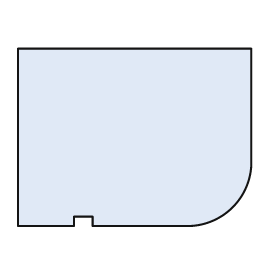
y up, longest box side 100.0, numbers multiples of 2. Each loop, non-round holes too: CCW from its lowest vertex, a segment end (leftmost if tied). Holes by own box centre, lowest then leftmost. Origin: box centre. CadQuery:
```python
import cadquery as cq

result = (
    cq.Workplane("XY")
    .moveTo(-50.0, -38.0)
    .lineTo(-26.0, -38.0)
    .lineTo(-26.0, -34.0)
    .lineTo(-18.0, -34.0)
    .lineTo(-18.0, -38.0)
    .lineTo(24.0, -38.0)
    .threePointArc((42.0, -30.0), (50.0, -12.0))
    .lineTo(50.0, 38.0)
    .lineTo(-50.0, 38.0)
    .close()
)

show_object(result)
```